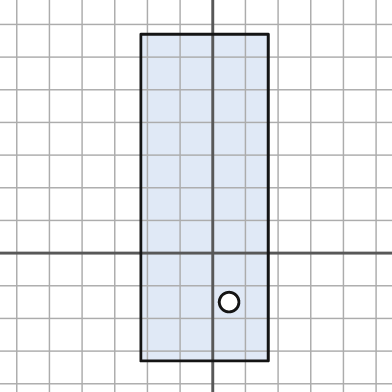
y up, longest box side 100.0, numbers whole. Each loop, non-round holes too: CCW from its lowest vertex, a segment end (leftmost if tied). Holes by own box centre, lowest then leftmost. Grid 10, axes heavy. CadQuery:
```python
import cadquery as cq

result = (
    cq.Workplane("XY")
    .moveTo(-22.0, -33.0)
    .lineTo(17.0, -33.0)
    .lineTo(17.0, 67.0)
    .lineTo(-22.0, 67.0)
    .close()
    .moveTo(5.0, -15.0)
    .circle(3.0)
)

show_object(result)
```